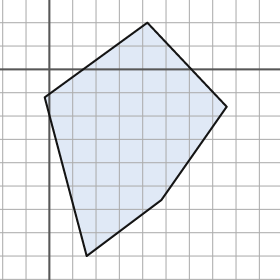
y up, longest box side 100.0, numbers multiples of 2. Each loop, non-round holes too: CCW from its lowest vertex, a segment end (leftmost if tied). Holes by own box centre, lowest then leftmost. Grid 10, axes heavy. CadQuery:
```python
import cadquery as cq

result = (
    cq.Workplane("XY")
    .moveTo(16.0, -80.0)
    .lineTo(48.0, -56.0)
    .lineTo(76.0, -16.0)
    .lineTo(42.0, 20.0)
    .lineTo(-2.0, -12.0)
    .close()
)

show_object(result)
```